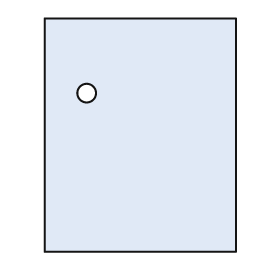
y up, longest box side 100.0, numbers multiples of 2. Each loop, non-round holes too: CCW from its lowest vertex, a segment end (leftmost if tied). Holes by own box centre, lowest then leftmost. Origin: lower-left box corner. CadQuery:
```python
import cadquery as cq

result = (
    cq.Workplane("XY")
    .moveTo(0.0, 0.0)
    .lineTo(82.0, 0.0)
    .lineTo(82.0, 100.0)
    .lineTo(0.0, 100.0)
    .close()
    .moveTo(18.0, 68.0)
    .circle(4.0)
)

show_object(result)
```